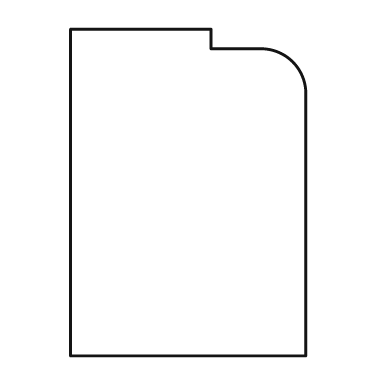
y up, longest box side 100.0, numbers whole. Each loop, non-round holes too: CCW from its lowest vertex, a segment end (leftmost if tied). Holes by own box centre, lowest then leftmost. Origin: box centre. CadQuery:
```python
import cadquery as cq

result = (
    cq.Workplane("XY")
    .moveTo(-36.0, -50.0)
    .lineTo(36.0, -50.0)
    .lineTo(36.0, 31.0)
    .threePointArc((32.0, 40.0), (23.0, 44.0))
    .lineTo(7.0, 44.0)
    .lineTo(7.0, 50.0)
    .lineTo(-36.0, 50.0)
    .close()
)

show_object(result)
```